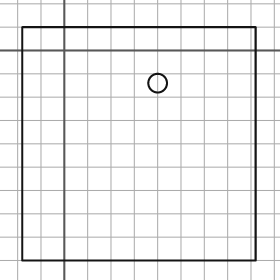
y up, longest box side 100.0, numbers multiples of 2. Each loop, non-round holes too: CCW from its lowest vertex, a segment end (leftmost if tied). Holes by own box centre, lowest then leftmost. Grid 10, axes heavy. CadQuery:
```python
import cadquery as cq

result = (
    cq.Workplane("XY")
    .moveTo(-18.0, -90.0)
    .lineTo(82.0, -90.0)
    .lineTo(82.0, 10.0)
    .lineTo(-18.0, 10.0)
    .close()
    .moveTo(40.0, -14.0)
    .circle(4.0)
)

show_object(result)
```